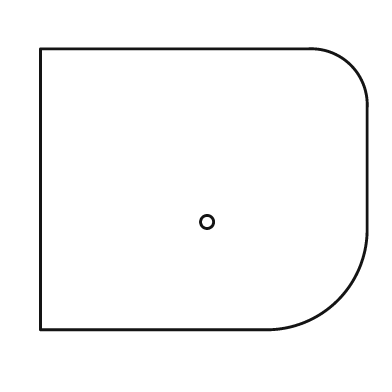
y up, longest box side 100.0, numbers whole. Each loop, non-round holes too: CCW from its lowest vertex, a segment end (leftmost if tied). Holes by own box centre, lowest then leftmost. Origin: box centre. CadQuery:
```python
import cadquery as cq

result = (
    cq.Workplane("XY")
    .moveTo(-50.0, -43.0)
    .lineTo(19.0, -43.0)
    .threePointArc((41.0, -34.0), (50.0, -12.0))
    .lineTo(50.0, 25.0)
    .threePointArc((45.0, 38.0), (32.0, 43.0))
    .lineTo(-50.0, 43.0)
    .close()
    .moveTo(1.0, -10.0)
    .circle(2.0)
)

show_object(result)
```